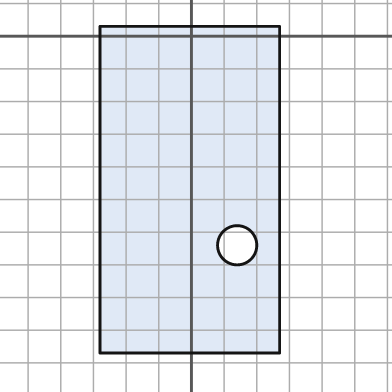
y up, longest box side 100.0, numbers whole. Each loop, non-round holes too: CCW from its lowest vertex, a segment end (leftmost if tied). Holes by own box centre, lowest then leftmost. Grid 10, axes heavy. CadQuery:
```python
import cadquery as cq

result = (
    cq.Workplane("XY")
    .moveTo(-28.0, -97.0)
    .lineTo(27.0, -97.0)
    .lineTo(27.0, 3.0)
    .lineTo(-28.0, 3.0)
    .close()
    .moveTo(14.0, -64.0)
    .circle(6.0)
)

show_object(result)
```